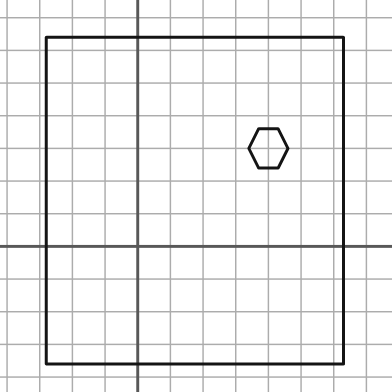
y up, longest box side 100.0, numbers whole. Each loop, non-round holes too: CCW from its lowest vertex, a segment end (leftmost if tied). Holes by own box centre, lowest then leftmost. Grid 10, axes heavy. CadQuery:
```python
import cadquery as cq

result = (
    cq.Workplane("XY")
    .moveTo(-28.0, -36.0)
    .lineTo(63.0, -36.0)
    .lineTo(63.0, 64.0)
    .lineTo(-28.0, 64.0)
    .close()
    .moveTo(37.0, 24.0)
    .lineTo(43.0, 24.0)
    .lineTo(46.0, 30.0)
    .lineTo(43.0, 36.0)
    .lineTo(37.0, 36.0)
    .lineTo(34.0, 30.0)
    .close()
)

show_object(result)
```